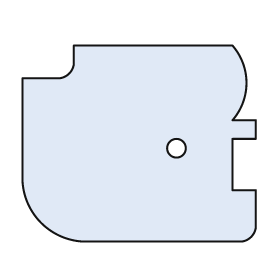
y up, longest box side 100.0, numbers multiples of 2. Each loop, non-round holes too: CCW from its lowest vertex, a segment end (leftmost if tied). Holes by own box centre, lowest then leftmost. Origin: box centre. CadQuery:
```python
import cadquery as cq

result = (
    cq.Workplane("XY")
    .moveTo(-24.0, -42.0)
    .lineTo(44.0, -42.0)
    .threePointArc((48.0, -40.0), (50.0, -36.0))
    .lineTo(50.0, -20.0)
    .lineTo(40.0, -20.0)
    .lineTo(40.0, 2.0)
    .lineTo(50.0, 2.0)
    .lineTo(50.0, 10.0)
    .lineTo(40.0, 10.0)
    .threePointArc((46.0, 26.0), (40.0, 42.0))
    .lineTo(-28.0, 42.0)
    .lineTo(-28.0, 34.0)
    .threePointArc((-30.0, 30.0), (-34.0, 28.0))
    .lineTo(-50.0, 28.0)
    .lineTo(-50.0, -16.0)
    .threePointArc((-42.0, -34.0), (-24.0, -42.0))
    .close()
    .moveTo(16.0, -2.0)
    .circle(4.0)
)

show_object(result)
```